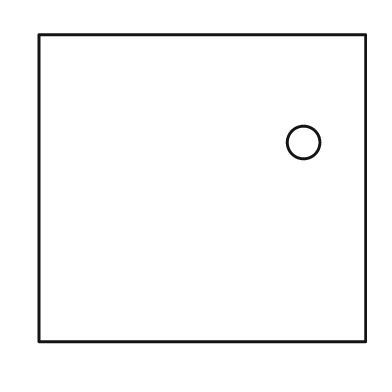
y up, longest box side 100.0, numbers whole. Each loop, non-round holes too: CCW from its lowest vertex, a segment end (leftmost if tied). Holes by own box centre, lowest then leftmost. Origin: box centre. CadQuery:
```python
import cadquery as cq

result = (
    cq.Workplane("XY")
    .moveTo(-50.0, -47.0)
    .lineTo(50.0, -47.0)
    .lineTo(50.0, 47.0)
    .lineTo(-50.0, 47.0)
    .close()
    .moveTo(31.0, 14.0)
    .circle(5.0)
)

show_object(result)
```